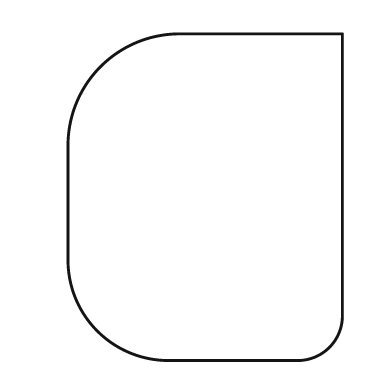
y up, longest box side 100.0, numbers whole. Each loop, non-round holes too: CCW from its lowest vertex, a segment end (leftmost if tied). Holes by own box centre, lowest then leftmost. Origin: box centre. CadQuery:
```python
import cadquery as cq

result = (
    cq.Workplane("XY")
    .moveTo(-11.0, -50.0)
    .lineTo(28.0, -50.0)
    .threePointArc((38.0, -46.0), (42.0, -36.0))
    .lineTo(42.0, 50.0)
    .lineTo(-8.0, 50.0)
    .threePointArc((-32.0, 40.0), (-42.0, 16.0))
    .lineTo(-42.0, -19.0)
    .threePointArc((-33.0, -41.0), (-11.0, -50.0))
    .close()
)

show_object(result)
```